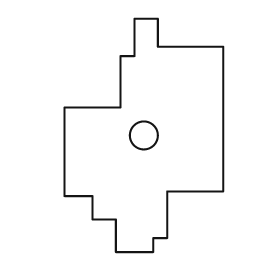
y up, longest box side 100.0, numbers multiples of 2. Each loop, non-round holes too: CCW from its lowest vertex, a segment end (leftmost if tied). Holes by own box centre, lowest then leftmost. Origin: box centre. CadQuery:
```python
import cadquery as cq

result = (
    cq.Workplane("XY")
    .moveTo(-12.0, -50.0)
    .lineTo(4.0, -50.0)
    .lineTo(4.0, -44.0)
    .lineTo(10.0, -44.0)
    .lineTo(10.0, -24.0)
    .lineTo(34.0, -24.0)
    .lineTo(34.0, 38.0)
    .lineTo(6.0, 38.0)
    .lineTo(6.0, 50.0)
    .lineTo(-4.0, 50.0)
    .lineTo(-4.0, 34.0)
    .lineTo(-10.0, 34.0)
    .lineTo(-10.0, 12.0)
    .lineTo(-34.0, 12.0)
    .lineTo(-34.0, -26.0)
    .lineTo(-22.0, -26.0)
    .lineTo(-22.0, -36.0)
    .lineTo(-12.0, -36.0)
    .close()
    .moveTo(0.0, 0.0)
    .circle(6.0)
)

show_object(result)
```